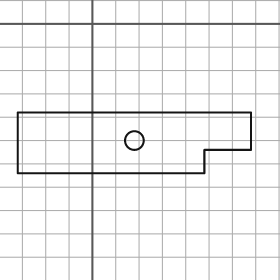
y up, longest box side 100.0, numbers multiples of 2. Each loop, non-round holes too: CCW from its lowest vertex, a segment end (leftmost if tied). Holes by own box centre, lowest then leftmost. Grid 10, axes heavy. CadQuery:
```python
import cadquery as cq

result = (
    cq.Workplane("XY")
    .moveTo(-32.0, -64.0)
    .lineTo(48.0, -64.0)
    .lineTo(48.0, -54.0)
    .lineTo(68.0, -54.0)
    .lineTo(68.0, -38.0)
    .lineTo(-32.0, -38.0)
    .close()
    .moveTo(18.0, -50.0)
    .circle(4.0)
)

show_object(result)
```